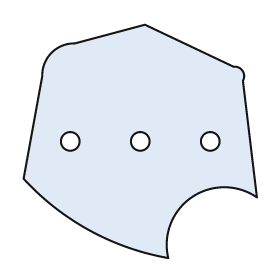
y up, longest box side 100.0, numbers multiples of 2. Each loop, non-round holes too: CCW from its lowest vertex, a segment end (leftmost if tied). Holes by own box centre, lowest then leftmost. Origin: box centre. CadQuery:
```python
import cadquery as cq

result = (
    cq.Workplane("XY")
    .moveTo(12.0, -50.0)
    .threePointArc((22.0, -24.0), (50.0, -24.0))
    .lineTo(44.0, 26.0)
    .threePointArc((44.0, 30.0), (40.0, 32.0))
    .lineTo(2.0, 50.0)
    .lineTo(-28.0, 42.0)
    .threePointArc((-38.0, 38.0), (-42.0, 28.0))
    .lineTo(-50.0, -16.0)
    .threePointArc((-22.0, -38.0), (12.0, -50.0))
    .close()
    .moveTo(-30.0, 0.0)
    .circle(4.0)
    .moveTo(0.0, 0.0)
    .circle(4.0)
    .moveTo(30.0, 0.0)
    .circle(4.0)
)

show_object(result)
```